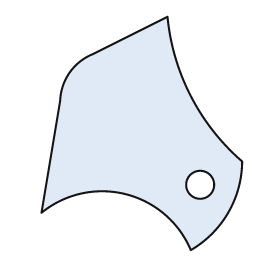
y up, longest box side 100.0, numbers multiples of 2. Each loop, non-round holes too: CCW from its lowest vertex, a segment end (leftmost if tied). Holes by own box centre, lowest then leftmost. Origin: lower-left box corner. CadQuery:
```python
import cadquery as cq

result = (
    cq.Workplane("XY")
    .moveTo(64.0, 0.0)
    .threePointArc((80.0, 16.0), (86.0, 38.0))
    .threePointArc((64.0, 66.0), (54.0, 100.0))
    .lineTo(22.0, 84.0)
    .threePointArc((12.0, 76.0), (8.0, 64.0))
    .lineTo(0.0, 16.0)
    .threePointArc((36.0, 24.0), (64.0, 0.0))
    .close()
    .moveTo(68.0, 28.0)
    .circle(6.0)
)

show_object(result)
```